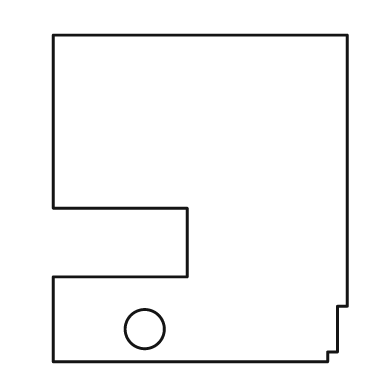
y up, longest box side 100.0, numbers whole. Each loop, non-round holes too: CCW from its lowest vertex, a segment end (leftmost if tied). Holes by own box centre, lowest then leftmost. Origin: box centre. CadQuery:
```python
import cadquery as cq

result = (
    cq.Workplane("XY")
    .moveTo(-45.0, -50.0)
    .lineTo(39.0, -50.0)
    .lineTo(39.0, -47.0)
    .lineTo(42.0, -47.0)
    .lineTo(42.0, -33.0)
    .lineTo(45.0, -33.0)
    .lineTo(45.0, 50.0)
    .lineTo(-45.0, 50.0)
    .lineTo(-45.0, -3.0)
    .lineTo(-4.0, -3.0)
    .lineTo(-4.0, -24.0)
    .lineTo(-45.0, -24.0)
    .close()
    .moveTo(-17.0, -40.0)
    .circle(6.0)
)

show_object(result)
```